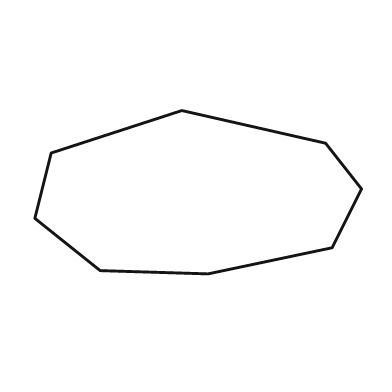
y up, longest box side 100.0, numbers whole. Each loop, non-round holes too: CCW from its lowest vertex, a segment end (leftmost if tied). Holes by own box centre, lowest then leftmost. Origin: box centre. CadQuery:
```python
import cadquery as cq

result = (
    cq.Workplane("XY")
    .moveTo(3.0, -25.0)
    .lineTo(41.0, -17.0)
    .lineTo(50.0, 1.0)
    .lineTo(39.0, 15.0)
    .lineTo(-5.0, 25.0)
    .lineTo(-45.0, 12.0)
    .lineTo(-50.0, -8.0)
    .lineTo(-30.0, -24.0)
    .close()
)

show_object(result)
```